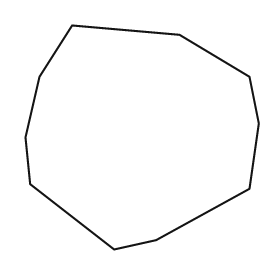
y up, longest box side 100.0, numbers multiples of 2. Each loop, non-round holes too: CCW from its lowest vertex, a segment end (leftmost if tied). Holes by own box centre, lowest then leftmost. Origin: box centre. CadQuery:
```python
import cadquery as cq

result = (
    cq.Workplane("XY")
    .moveTo(-12.0, -48.0)
    .lineTo(6.0, -44.0)
    .lineTo(46.0, -22.0)
    .lineTo(50.0, 6.0)
    .lineTo(46.0, 26.0)
    .lineTo(16.0, 44.0)
    .lineTo(-30.0, 48.0)
    .lineTo(-44.0, 26.0)
    .lineTo(-50.0, 0.0)
    .lineTo(-48.0, -20.0)
    .close()
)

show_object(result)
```